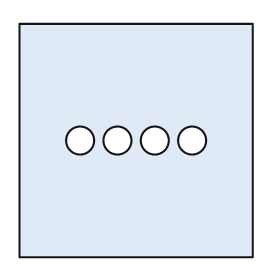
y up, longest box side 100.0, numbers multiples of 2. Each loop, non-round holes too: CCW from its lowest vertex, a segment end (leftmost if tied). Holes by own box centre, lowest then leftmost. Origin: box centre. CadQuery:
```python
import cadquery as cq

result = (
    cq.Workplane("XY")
    .moveTo(-50.0, -50.0)
    .lineTo(50.0, -50.0)
    .lineTo(50.0, 50.0)
    .lineTo(-50.0, 50.0)
    .close()
    .moveTo(-24.0, 0.0)
    .circle(6.0)
    .moveTo(-8.0, 0.0)
    .circle(6.0)
    .moveTo(8.0, 0.0)
    .circle(6.0)
    .moveTo(24.0, 0.0)
    .circle(6.0)
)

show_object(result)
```